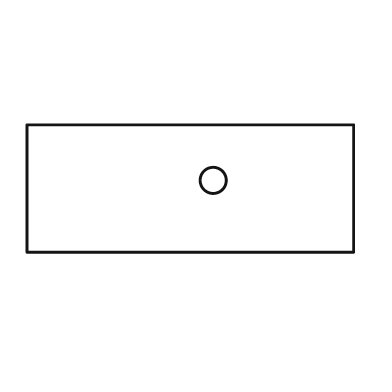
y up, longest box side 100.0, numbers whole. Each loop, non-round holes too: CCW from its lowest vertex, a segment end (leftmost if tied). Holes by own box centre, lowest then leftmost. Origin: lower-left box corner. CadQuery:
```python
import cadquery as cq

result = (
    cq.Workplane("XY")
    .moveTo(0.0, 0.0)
    .lineTo(100.0, 0.0)
    .lineTo(100.0, 39.0)
    .lineTo(0.0, 39.0)
    .close()
    .moveTo(57.0, 22.0)
    .circle(4.0)
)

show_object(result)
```